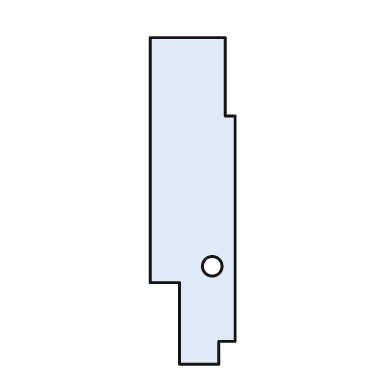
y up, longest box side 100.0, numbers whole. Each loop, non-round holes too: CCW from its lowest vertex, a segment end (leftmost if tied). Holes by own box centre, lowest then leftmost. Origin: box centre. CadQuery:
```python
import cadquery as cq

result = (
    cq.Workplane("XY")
    .moveTo(-4.0, -50.0)
    .lineTo(8.0, -50.0)
    .lineTo(8.0, -43.0)
    .lineTo(13.0, -43.0)
    .lineTo(13.0, 26.0)
    .lineTo(10.0, 26.0)
    .lineTo(10.0, 50.0)
    .lineTo(-13.0, 50.0)
    .lineTo(-13.0, -25.0)
    .lineTo(-4.0, -25.0)
    .close()
    .moveTo(6.0, -20.0)
    .circle(3.0)
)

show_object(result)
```